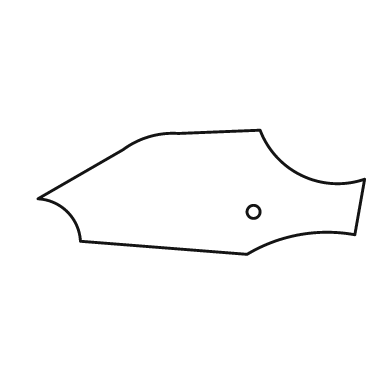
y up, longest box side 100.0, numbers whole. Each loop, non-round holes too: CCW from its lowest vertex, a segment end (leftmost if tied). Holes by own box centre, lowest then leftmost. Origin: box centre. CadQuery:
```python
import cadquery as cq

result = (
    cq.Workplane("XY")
    .moveTo(14.0, -19.0)
    .threePointArc((30.0, -13.0), (47.0, -13.0))
    .lineTo(50.0, 4.0)
    .threePointArc((31.0, 5.0), (18.0, 19.0))
    .lineTo(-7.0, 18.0)
    .threePointArc((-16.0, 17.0), (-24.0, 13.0))
    .lineTo(-50.0, -2.0)
    .threePointArc((-41.0, -6.0), (-37.0, -15.0))
    .close()
    .moveTo(16.0, -6.0)
    .circle(2.0)
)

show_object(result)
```